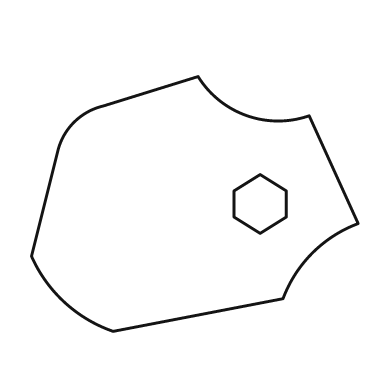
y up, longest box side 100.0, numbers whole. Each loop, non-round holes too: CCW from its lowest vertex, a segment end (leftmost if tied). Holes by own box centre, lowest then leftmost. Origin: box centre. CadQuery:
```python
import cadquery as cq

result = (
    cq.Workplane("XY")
    .moveTo(-25.0, -39.0)
    .lineTo(27.0, -29.0)
    .threePointArc((36.0, -15.0), (50.0, -6.0))
    .lineTo(35.0, 27.0)
    .threePointArc((16.0, 27.0), (1.0, 39.0))
    .lineTo(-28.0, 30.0)
    .threePointArc((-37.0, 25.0), (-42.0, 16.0))
    .lineTo(-50.0, -16.0)
    .threePointArc((-40.0, -30.0), (-25.0, -39.0))
    .close()
    .moveTo(20.0, -9.0)
    .lineTo(28.0, -4.0)
    .lineTo(28.0, 4.0)
    .lineTo(20.0, 9.0)
    .lineTo(12.0, 4.0)
    .lineTo(12.0, -4.0)
    .close()
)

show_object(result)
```